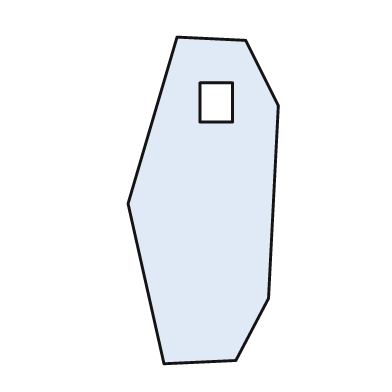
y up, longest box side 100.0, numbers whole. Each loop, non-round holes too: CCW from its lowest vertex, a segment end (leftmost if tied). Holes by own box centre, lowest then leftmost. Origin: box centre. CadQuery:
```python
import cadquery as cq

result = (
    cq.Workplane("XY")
    .moveTo(-12.0, -50.0)
    .lineTo(10.0, -49.0)
    .lineTo(20.0, -30.0)
    .lineTo(23.0, 29.0)
    .lineTo(13.0, 49.0)
    .lineTo(-8.0, 50.0)
    .lineTo(-23.0, -1.0)
    .close()
    .moveTo(-1.0, 24.0)
    .lineTo(9.0, 24.0)
    .lineTo(9.0, 36.0)
    .lineTo(-1.0, 36.0)
    .close()
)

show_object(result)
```